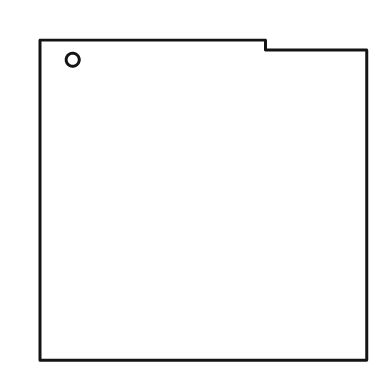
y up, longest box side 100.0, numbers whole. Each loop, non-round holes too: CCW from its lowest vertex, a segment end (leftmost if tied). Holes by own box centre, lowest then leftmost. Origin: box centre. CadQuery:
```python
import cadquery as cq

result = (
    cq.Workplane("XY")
    .moveTo(-50.0, -49.0)
    .lineTo(50.0, -49.0)
    .lineTo(50.0, 46.0)
    .lineTo(19.0, 46.0)
    .lineTo(19.0, 49.0)
    .lineTo(-50.0, 49.0)
    .close()
    .moveTo(-40.0, 43.0)
    .circle(2.0)
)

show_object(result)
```